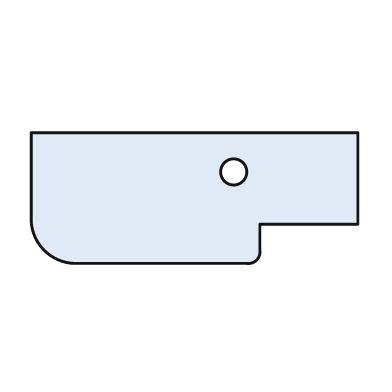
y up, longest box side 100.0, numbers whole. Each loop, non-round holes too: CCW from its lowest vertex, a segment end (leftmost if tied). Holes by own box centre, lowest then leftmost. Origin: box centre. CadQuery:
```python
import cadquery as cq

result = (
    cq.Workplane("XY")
    .moveTo(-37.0, -20.0)
    .lineTo(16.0, -20.0)
    .threePointArc((19.0, -19.0), (20.0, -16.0))
    .lineTo(20.0, -8.0)
    .lineTo(50.0, -8.0)
    .lineTo(50.0, 20.0)
    .lineTo(-50.0, 20.0)
    .lineTo(-50.0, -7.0)
    .threePointArc((-46.0, -16.0), (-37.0, -20.0))
    .close()
    .moveTo(12.0, 8.0)
    .circle(4.0)
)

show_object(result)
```